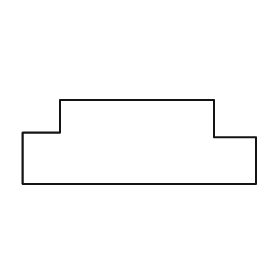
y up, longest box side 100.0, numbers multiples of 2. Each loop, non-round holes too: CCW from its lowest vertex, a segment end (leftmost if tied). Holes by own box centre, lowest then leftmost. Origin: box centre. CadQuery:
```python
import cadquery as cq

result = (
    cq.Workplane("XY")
    .moveTo(-50.0, -18.0)
    .lineTo(50.0, -18.0)
    .lineTo(50.0, 2.0)
    .lineTo(32.0, 2.0)
    .lineTo(32.0, 18.0)
    .lineTo(-34.0, 18.0)
    .lineTo(-34.0, 4.0)
    .lineTo(-50.0, 4.0)
    .close()
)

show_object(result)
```